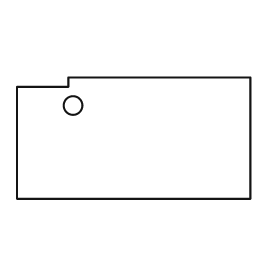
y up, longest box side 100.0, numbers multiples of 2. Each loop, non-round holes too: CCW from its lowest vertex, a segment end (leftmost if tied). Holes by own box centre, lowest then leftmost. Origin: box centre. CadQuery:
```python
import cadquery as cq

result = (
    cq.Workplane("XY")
    .moveTo(-50.0, -26.0)
    .lineTo(50.0, -26.0)
    .lineTo(50.0, 26.0)
    .lineTo(-28.0, 26.0)
    .lineTo(-28.0, 22.0)
    .lineTo(-50.0, 22.0)
    .close()
    .moveTo(-26.0, 14.0)
    .circle(4.0)
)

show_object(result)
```